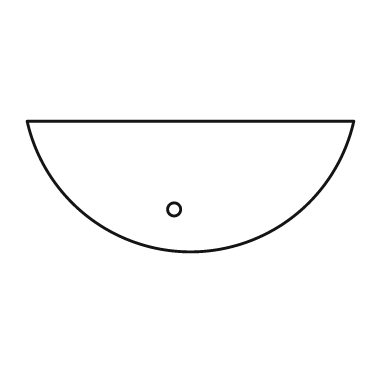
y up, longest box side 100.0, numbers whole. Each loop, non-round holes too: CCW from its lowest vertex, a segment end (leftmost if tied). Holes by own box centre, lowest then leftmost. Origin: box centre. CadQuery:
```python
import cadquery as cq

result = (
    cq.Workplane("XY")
    .moveTo(-50.0, 20.0)
    .threePointArc((0.0, -20.0), (50.0, 20.0))
    .close()
    .moveTo(-5.0, -7.0)
    .circle(2.0)
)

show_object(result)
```